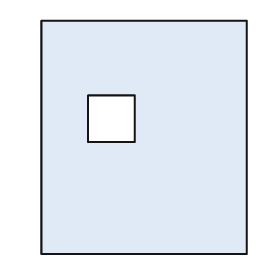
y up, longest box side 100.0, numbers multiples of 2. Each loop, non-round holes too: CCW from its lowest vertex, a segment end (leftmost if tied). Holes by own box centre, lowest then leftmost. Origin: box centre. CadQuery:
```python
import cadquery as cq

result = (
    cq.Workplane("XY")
    .moveTo(-44.0, -50.0)
    .lineTo(44.0, -50.0)
    .lineTo(44.0, 50.0)
    .lineTo(-44.0, 50.0)
    .close()
    .moveTo(-24.0, -2.0)
    .lineTo(-4.0, -2.0)
    .lineTo(-4.0, 18.0)
    .lineTo(-24.0, 18.0)
    .close()
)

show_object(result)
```